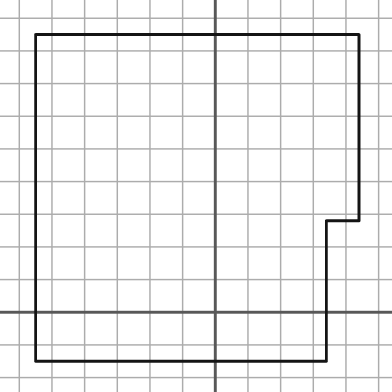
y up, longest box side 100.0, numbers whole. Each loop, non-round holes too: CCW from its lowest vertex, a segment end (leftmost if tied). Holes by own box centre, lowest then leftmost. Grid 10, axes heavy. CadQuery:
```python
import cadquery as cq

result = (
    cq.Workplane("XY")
    .moveTo(-55.0, -15.0)
    .lineTo(34.0, -15.0)
    .lineTo(34.0, 28.0)
    .lineTo(44.0, 28.0)
    .lineTo(44.0, 85.0)
    .lineTo(-55.0, 85.0)
    .close()
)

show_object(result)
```